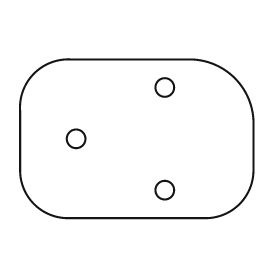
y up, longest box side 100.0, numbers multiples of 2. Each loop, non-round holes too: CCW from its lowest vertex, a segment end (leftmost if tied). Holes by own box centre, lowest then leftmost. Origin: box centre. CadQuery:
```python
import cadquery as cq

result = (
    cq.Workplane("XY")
    .moveTo(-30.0, -34.0)
    .lineTo(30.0, -34.0)
    .threePointArc((44.0, -28.0), (50.0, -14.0))
    .lineTo(50.0, 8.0)
    .threePointArc((42.0, 26.0), (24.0, 34.0))
    .lineTo(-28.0, 34.0)
    .threePointArc((-44.0, 28.0), (-50.0, 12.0))
    .lineTo(-50.0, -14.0)
    .threePointArc((-44.0, -28.0), (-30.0, -34.0))
    .close()
    .moveTo(12.0, -22.0)
    .circle(4.0)
    .moveTo(-26.0, 0.0)
    .circle(4.0)
    .moveTo(12.0, 22.0)
    .circle(4.0)
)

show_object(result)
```